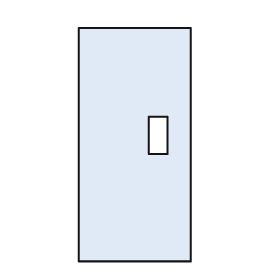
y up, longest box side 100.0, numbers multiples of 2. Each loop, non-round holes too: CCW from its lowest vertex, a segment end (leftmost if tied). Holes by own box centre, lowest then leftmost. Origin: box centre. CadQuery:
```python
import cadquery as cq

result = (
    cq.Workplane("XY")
    .moveTo(-24.0, -50.0)
    .lineTo(24.0, -50.0)
    .lineTo(24.0, 50.0)
    .lineTo(-24.0, 50.0)
    .close()
    .moveTo(6.0, -4.0)
    .lineTo(14.0, -4.0)
    .lineTo(14.0, 12.0)
    .lineTo(6.0, 12.0)
    .close()
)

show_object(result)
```